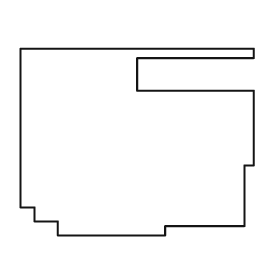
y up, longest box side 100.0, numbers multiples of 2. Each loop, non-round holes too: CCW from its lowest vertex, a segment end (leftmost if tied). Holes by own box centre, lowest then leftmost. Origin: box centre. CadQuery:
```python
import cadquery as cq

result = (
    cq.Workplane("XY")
    .moveTo(-34.0, -40.0)
    .lineTo(12.0, -40.0)
    .lineTo(12.0, -36.0)
    .lineTo(46.0, -36.0)
    .lineTo(46.0, -10.0)
    .lineTo(50.0, -10.0)
    .lineTo(50.0, 22.0)
    .lineTo(0.0, 22.0)
    .lineTo(0.0, 36.0)
    .lineTo(50.0, 36.0)
    .lineTo(50.0, 40.0)
    .lineTo(-50.0, 40.0)
    .lineTo(-50.0, -28.0)
    .lineTo(-44.0, -28.0)
    .lineTo(-44.0, -34.0)
    .lineTo(-34.0, -34.0)
    .close()
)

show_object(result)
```